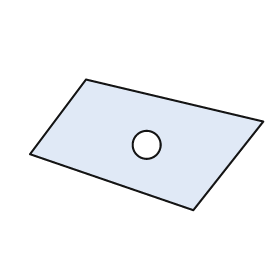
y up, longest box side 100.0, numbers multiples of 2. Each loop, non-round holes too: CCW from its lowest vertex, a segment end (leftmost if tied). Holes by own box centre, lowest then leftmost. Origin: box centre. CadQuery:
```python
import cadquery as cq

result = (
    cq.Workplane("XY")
    .moveTo(20.0, -28.0)
    .lineTo(50.0, 10.0)
    .lineTo(-26.0, 28.0)
    .lineTo(-50.0, -4.0)
    .close()
    .moveTo(0.0, 0.0)
    .circle(6.0)
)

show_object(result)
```